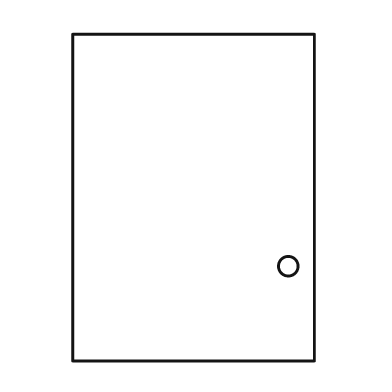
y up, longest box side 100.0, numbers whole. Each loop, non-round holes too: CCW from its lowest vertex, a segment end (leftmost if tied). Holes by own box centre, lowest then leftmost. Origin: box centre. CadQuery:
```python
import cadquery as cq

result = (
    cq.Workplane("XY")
    .moveTo(-37.0, -50.0)
    .lineTo(37.0, -50.0)
    .lineTo(37.0, 50.0)
    .lineTo(-37.0, 50.0)
    .close()
    .moveTo(29.0, -21.0)
    .circle(3.0)
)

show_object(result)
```